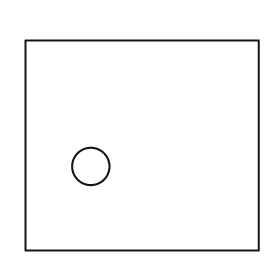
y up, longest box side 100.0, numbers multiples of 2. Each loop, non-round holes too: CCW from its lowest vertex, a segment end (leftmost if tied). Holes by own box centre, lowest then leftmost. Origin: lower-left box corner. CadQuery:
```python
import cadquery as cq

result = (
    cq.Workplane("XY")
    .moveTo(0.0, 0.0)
    .lineTo(100.0, 0.0)
    .lineTo(100.0, 90.0)
    .lineTo(0.0, 90.0)
    .close()
    .moveTo(28.0, 36.0)
    .circle(8.0)
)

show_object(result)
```